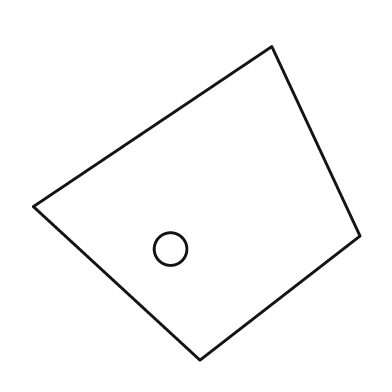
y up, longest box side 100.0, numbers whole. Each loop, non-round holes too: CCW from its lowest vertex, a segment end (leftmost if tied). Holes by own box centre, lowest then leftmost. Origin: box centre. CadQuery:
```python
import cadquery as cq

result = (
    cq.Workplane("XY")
    .moveTo(1.0, -48.0)
    .lineTo(50.0, -10.0)
    .lineTo(23.0, 48.0)
    .lineTo(-50.0, -1.0)
    .close()
    .moveTo(-8.0, -14.0)
    .circle(5.0)
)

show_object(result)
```